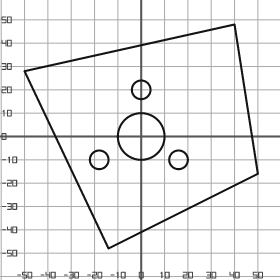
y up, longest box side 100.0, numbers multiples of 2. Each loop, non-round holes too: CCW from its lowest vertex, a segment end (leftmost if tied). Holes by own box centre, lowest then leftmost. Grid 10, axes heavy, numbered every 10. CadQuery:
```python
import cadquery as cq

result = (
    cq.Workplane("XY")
    .moveTo(-14.0, -48.0)
    .lineTo(50.0, -16.0)
    .lineTo(40.0, 48.0)
    .lineTo(-50.0, 28.0)
    .close()
    .moveTo(-18.0, -10.0)
    .circle(4.0)
    .moveTo(16.0, -10.0)
    .circle(4.0)
    .moveTo(0.0, 0.0)
    .circle(10.0)
    .moveTo(0.0, 20.0)
    .circle(4.0)
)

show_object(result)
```